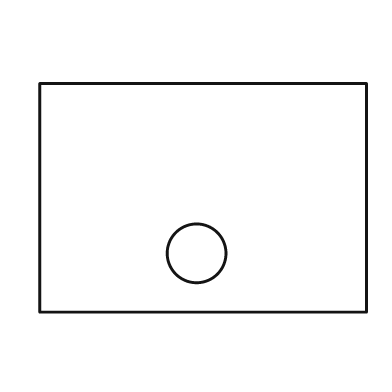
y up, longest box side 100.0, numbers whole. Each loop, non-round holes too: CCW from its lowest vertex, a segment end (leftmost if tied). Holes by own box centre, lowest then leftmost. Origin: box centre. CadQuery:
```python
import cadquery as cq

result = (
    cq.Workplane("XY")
    .moveTo(-50.0, -35.0)
    .lineTo(50.0, -35.0)
    .lineTo(50.0, 35.0)
    .lineTo(-50.0, 35.0)
    .close()
    .moveTo(-2.0, -17.0)
    .circle(9.0)
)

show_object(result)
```